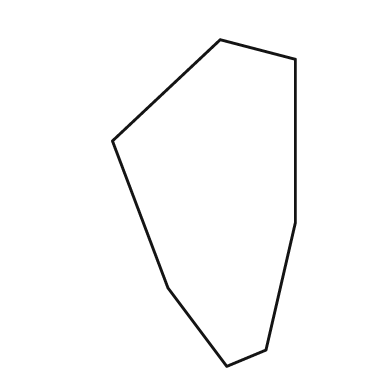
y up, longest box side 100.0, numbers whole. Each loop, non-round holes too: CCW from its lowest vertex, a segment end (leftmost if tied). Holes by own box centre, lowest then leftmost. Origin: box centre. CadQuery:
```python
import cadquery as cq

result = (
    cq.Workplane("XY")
    .moveTo(7.0, -50.0)
    .lineTo(19.0, -45.0)
    .lineTo(28.0, -6.0)
    .lineTo(28.0, 44.0)
    .lineTo(5.0, 50.0)
    .lineTo(-28.0, 19.0)
    .lineTo(-11.0, -26.0)
    .close()
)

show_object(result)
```